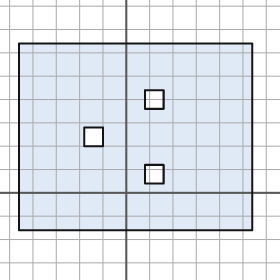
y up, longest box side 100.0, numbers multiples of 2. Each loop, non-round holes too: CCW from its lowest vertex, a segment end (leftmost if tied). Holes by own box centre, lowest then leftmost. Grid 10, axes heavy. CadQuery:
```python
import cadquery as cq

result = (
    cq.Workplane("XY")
    .moveTo(-46.0, -16.0)
    .lineTo(54.0, -16.0)
    .lineTo(54.0, 64.0)
    .lineTo(-46.0, 64.0)
    .close()
    .moveTo(8.0, 4.0)
    .lineTo(16.0, 4.0)
    .lineTo(16.0, 12.0)
    .lineTo(8.0, 12.0)
    .close()
    .moveTo(-18.0, 20.0)
    .lineTo(-10.0, 20.0)
    .lineTo(-10.0, 28.0)
    .lineTo(-18.0, 28.0)
    .close()
    .moveTo(8.0, 36.0)
    .lineTo(16.0, 36.0)
    .lineTo(16.0, 44.0)
    .lineTo(8.0, 44.0)
    .close()
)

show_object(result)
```